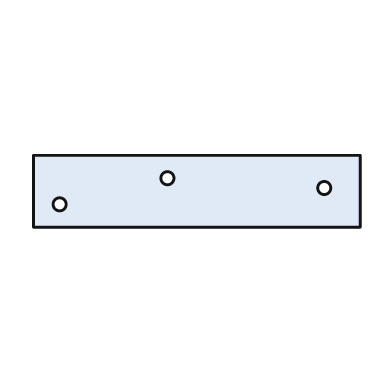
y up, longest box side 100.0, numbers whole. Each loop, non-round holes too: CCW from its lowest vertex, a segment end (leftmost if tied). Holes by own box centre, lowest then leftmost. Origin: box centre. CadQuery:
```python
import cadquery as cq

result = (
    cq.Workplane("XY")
    .moveTo(-50.0, -11.0)
    .lineTo(50.0, -11.0)
    .lineTo(50.0, 11.0)
    .lineTo(-50.0, 11.0)
    .close()
    .moveTo(-42.0, -4.0)
    .circle(2.0)
    .moveTo(39.0, 1.0)
    .circle(2.0)
    .moveTo(-9.0, 4.0)
    .circle(2.0)
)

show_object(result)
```